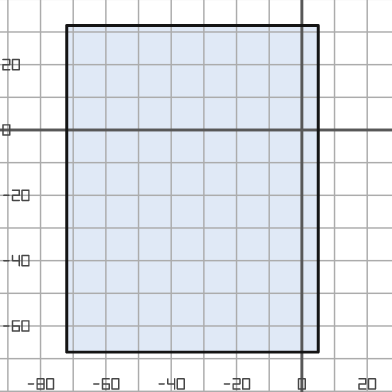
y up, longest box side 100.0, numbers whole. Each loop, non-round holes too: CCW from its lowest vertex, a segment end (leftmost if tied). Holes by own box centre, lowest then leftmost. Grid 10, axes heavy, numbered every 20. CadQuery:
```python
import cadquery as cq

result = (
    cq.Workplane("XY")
    .moveTo(-72.0, -68.0)
    .lineTo(5.0, -68.0)
    .lineTo(5.0, 32.0)
    .lineTo(-72.0, 32.0)
    .close()
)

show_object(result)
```